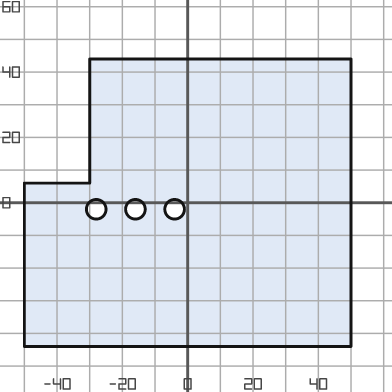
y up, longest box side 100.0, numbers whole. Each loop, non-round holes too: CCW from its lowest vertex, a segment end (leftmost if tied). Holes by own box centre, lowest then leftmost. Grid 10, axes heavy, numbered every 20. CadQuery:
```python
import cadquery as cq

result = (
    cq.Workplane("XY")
    .moveTo(-50.0, -44.0)
    .lineTo(50.0, -44.0)
    .lineTo(50.0, 44.0)
    .lineTo(-30.0, 44.0)
    .lineTo(-30.0, 6.0)
    .lineTo(-50.0, 6.0)
    .close()
    .moveTo(-28.0, -2.0)
    .circle(3.0)
    .moveTo(-16.0, -2.0)
    .circle(3.0)
    .moveTo(-4.0, -2.0)
    .circle(3.0)
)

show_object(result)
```